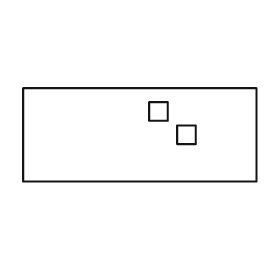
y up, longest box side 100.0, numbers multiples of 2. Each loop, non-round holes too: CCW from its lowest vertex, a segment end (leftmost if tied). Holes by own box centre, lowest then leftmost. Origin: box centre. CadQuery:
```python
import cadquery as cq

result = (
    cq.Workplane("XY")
    .moveTo(-50.0, -20.0)
    .lineTo(50.0, -20.0)
    .lineTo(50.0, 20.0)
    .lineTo(-50.0, 20.0)
    .close()
    .moveTo(16.0, -4.0)
    .lineTo(24.0, -4.0)
    .lineTo(24.0, 4.0)
    .lineTo(16.0, 4.0)
    .close()
    .moveTo(4.0, 6.0)
    .lineTo(12.0, 6.0)
    .lineTo(12.0, 14.0)
    .lineTo(4.0, 14.0)
    .close()
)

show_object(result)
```